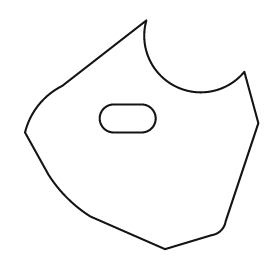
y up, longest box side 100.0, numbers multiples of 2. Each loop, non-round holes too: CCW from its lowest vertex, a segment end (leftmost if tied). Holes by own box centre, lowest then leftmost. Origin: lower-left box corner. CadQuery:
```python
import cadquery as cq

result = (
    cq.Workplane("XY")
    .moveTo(60.0, 0.0)
    .lineTo(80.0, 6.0)
    .threePointArc((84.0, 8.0), (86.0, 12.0))
    .lineTo(100.0, 54.0)
    .lineTo(94.0, 76.0)
    .threePointArc((64.0, 70.0), (52.0, 98.0))
    .lineTo(16.0, 70.0)
    .threePointArc((6.0, 62.0), (0.0, 50.0))
    .lineTo(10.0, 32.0)
    .threePointArc((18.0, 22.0), (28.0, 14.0))
    .close()
    .moveTo(38.0, 50.0)
    .lineTo(50.0, 50.0)
    .threePointArc((56.0, 56.0), (50.0, 62.0))
    .lineTo(38.0, 62.0)
    .threePointArc((32.0, 56.0), (38.0, 50.0))
    .close()
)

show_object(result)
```